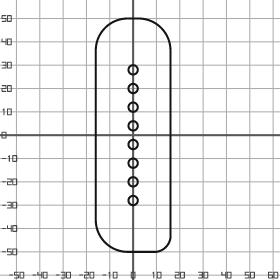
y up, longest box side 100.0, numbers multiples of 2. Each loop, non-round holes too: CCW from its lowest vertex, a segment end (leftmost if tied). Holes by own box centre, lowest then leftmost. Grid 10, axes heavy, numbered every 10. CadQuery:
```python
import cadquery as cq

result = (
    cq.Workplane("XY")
    .moveTo(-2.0, -50.0)
    .lineTo(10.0, -50.0)
    .threePointArc((14.0, -48.0), (16.0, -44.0))
    .lineTo(16.0, 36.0)
    .threePointArc((12.0, 46.0), (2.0, 50.0))
    .lineTo(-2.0, 50.0)
    .threePointArc((-12.0, 46.0), (-16.0, 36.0))
    .lineTo(-16.0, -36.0)
    .threePointArc((-12.0, -46.0), (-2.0, -50.0))
    .close()
    .moveTo(0.0, -28.0)
    .circle(2.0)
    .moveTo(0.0, -20.0)
    .circle(2.0)
    .moveTo(0.0, -12.0)
    .circle(2.0)
    .moveTo(0.0, -4.0)
    .circle(2.0)
    .moveTo(0.0, 4.0)
    .circle(2.0)
    .moveTo(0.0, 12.0)
    .circle(2.0)
    .moveTo(0.0, 20.0)
    .circle(2.0)
    .moveTo(0.0, 28.0)
    .circle(2.0)
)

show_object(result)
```